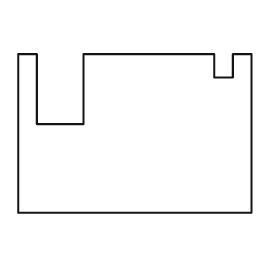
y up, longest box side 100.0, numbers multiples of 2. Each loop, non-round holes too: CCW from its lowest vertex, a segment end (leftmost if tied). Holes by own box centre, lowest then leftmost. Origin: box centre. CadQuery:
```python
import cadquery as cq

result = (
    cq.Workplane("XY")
    .moveTo(-50.0, -34.0)
    .lineTo(50.0, -34.0)
    .lineTo(50.0, 34.0)
    .lineTo(42.0, 34.0)
    .lineTo(42.0, 24.0)
    .lineTo(34.0, 24.0)
    .lineTo(34.0, 34.0)
    .lineTo(-22.0, 34.0)
    .lineTo(-22.0, 4.0)
    .lineTo(-42.0, 4.0)
    .lineTo(-42.0, 34.0)
    .lineTo(-50.0, 34.0)
    .close()
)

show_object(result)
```